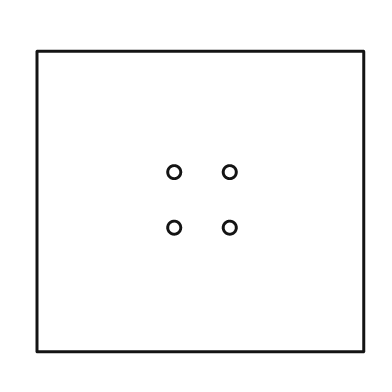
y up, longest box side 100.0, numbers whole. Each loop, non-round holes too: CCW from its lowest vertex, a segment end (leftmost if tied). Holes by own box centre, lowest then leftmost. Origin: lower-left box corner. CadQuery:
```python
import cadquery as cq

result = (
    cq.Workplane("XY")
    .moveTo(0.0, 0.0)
    .lineTo(100.0, 0.0)
    .lineTo(100.0, 92.0)
    .lineTo(0.0, 92.0)
    .close()
    .moveTo(42.0, 38.0)
    .circle(2.0)
    .moveTo(59.0, 38.0)
    .circle(2.0)
    .moveTo(42.0, 55.0)
    .circle(2.0)
    .moveTo(59.0, 55.0)
    .circle(2.0)
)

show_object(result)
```